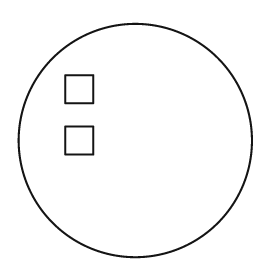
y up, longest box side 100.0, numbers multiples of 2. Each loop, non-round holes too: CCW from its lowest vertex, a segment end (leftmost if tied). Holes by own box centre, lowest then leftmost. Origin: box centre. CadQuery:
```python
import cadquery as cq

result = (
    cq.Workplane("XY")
    .moveTo(0.0, 0.0)
    .circle(50.0)
    .moveTo(-30.0, -6.0)
    .lineTo(-18.0, -6.0)
    .lineTo(-18.0, 6.0)
    .lineTo(-30.0, 6.0)
    .close()
    .moveTo(-30.0, 16.0)
    .lineTo(-18.0, 16.0)
    .lineTo(-18.0, 28.0)
    .lineTo(-30.0, 28.0)
    .close()
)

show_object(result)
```